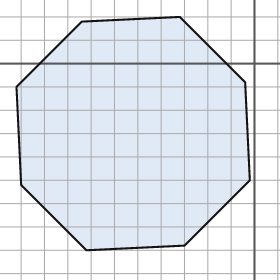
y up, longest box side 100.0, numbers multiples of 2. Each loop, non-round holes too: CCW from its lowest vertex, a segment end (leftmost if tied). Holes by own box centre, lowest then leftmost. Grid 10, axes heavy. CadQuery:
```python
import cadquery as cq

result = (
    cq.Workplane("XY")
    .moveTo(-72.0, -80.0)
    .lineTo(-30.0, -78.0)
    .lineTo(-2.0, -50.0)
    .lineTo(-4.0, -8.0)
    .lineTo(-32.0, 20.0)
    .lineTo(-74.0, 18.0)
    .lineTo(-102.0, -10.0)
    .lineTo(-100.0, -52.0)
    .close()
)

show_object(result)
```